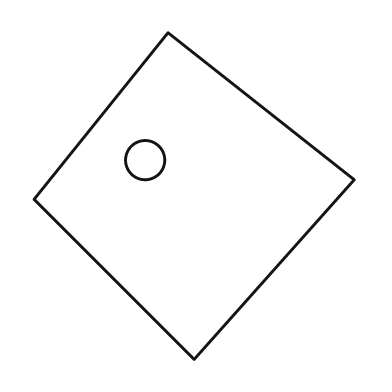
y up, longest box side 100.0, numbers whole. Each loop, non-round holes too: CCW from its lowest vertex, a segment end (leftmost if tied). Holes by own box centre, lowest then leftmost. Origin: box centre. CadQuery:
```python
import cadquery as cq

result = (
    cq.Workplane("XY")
    .moveTo(0.0, -50.0)
    .lineTo(49.0, 5.0)
    .lineTo(-8.0, 50.0)
    .lineTo(-49.0, -1.0)
    .close()
    .moveTo(-15.0, 11.0)
    .circle(6.0)
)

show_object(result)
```